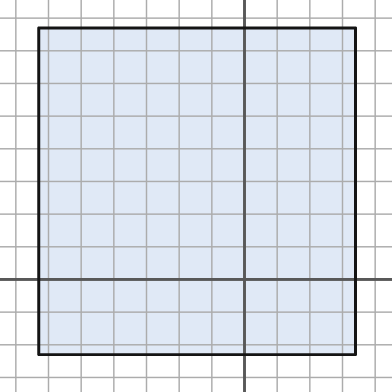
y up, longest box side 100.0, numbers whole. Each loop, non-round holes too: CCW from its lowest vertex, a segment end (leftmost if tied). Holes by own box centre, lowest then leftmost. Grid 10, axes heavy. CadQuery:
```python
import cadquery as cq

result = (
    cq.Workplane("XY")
    .moveTo(-63.0, -23.0)
    .lineTo(34.0, -23.0)
    .lineTo(34.0, 77.0)
    .lineTo(-63.0, 77.0)
    .close()
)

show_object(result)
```